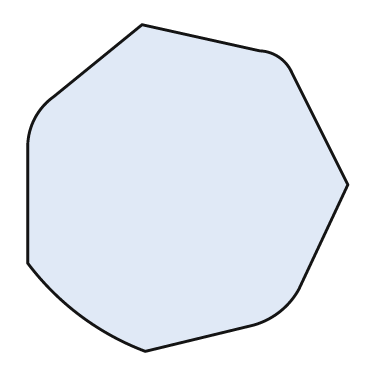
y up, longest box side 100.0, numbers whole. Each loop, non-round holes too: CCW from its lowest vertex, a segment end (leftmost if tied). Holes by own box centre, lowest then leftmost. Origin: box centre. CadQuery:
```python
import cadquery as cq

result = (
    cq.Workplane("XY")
    .moveTo(-13.0, -50.0)
    .lineTo(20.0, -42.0)
    .threePointArc((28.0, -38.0), (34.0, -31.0))
    .lineTo(49.0, 1.0)
    .lineTo(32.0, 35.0)
    .threePointArc((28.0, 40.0), (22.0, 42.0))
    .lineTo(-14.0, 50.0)
    .lineTo(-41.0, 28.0)
    .threePointArc((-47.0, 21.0), (-49.0, 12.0))
    .lineTo(-49.0, -23.0)
    .threePointArc((-33.0, -39.0), (-13.0, -50.0))
    .close()
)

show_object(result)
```